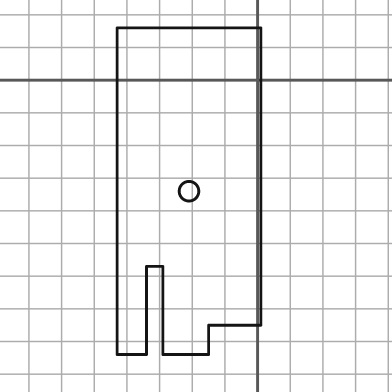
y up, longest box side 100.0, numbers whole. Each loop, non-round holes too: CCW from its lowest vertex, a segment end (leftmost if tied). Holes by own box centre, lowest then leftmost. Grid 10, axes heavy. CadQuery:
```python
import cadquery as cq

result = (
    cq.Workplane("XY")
    .moveTo(-43.0, -84.0)
    .lineTo(-34.0, -84.0)
    .lineTo(-34.0, -57.0)
    .lineTo(-29.0, -57.0)
    .lineTo(-29.0, -84.0)
    .lineTo(-15.0, -84.0)
    .lineTo(-15.0, -75.0)
    .lineTo(1.0, -75.0)
    .lineTo(1.0, 16.0)
    .lineTo(-43.0, 16.0)
    .close()
    .moveTo(-21.0, -34.0)
    .circle(3.0)
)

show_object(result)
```